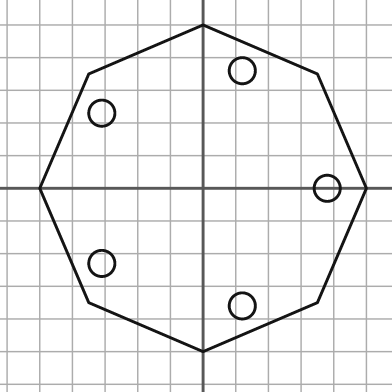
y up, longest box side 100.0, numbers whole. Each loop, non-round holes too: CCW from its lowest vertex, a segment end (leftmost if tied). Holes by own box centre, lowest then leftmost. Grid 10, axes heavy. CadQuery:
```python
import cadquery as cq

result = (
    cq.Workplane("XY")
    .moveTo(0.0, -50.0)
    .lineTo(35.0, -35.0)
    .lineTo(50.0, 0.0)
    .lineTo(35.0, 35.0)
    .lineTo(0.0, 50.0)
    .lineTo(-35.0, 35.0)
    .lineTo(-50.0, 0.0)
    .lineTo(-35.0, -35.0)
    .close()
    .moveTo(12.0, -36.0)
    .circle(4.0)
    .moveTo(-31.0, -23.0)
    .circle(4.0)
    .moveTo(38.0, 0.0)
    .circle(4.0)
    .moveTo(-31.0, 23.0)
    .circle(4.0)
    .moveTo(12.0, 36.0)
    .circle(4.0)
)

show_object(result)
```